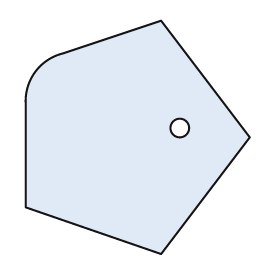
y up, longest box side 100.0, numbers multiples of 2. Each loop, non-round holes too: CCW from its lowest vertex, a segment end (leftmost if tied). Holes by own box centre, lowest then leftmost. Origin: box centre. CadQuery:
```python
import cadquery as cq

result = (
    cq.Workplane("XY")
    .moveTo(10.0, -50.0)
    .lineTo(48.0, 0.0)
    .lineTo(10.0, 50.0)
    .lineTo(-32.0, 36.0)
    .threePointArc((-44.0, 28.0), (-48.0, 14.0))
    .lineTo(-48.0, -30.0)
    .close()
    .moveTo(18.0, 4.0)
    .circle(4.0)
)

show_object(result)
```